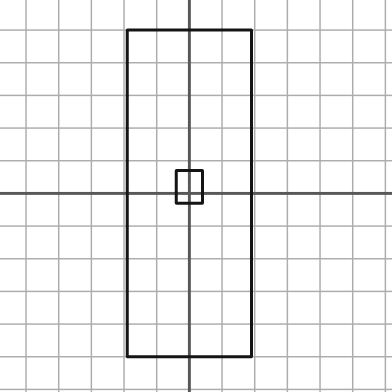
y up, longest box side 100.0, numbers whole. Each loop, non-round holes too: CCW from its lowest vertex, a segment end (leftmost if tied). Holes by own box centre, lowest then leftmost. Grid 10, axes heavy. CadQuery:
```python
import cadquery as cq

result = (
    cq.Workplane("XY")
    .moveTo(-19.0, -50.0)
    .lineTo(19.0, -50.0)
    .lineTo(19.0, 50.0)
    .lineTo(-19.0, 50.0)
    .close()
    .moveTo(-4.0, -3.0)
    .lineTo(4.0, -3.0)
    .lineTo(4.0, 7.0)
    .lineTo(-4.0, 7.0)
    .close()
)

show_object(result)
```